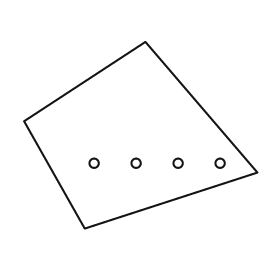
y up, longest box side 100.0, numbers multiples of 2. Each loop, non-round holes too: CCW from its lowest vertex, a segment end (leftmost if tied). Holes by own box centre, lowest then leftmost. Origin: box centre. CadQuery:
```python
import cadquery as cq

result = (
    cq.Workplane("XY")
    .moveTo(-24.0, -40.0)
    .lineTo(50.0, -16.0)
    .lineTo(2.0, 40.0)
    .lineTo(-50.0, 6.0)
    .close()
    .moveTo(-20.0, -12.0)
    .circle(2.0)
    .moveTo(-2.0, -12.0)
    .circle(2.0)
    .moveTo(16.0, -12.0)
    .circle(2.0)
    .moveTo(34.0, -12.0)
    .circle(2.0)
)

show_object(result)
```